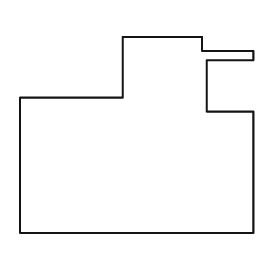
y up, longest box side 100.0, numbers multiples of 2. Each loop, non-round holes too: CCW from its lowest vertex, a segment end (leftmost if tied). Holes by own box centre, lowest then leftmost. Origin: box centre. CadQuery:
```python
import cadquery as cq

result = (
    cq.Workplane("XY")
    .moveTo(-50.0, -42.0)
    .lineTo(50.0, -42.0)
    .lineTo(50.0, 10.0)
    .lineTo(30.0, 10.0)
    .lineTo(30.0, 32.0)
    .lineTo(50.0, 32.0)
    .lineTo(50.0, 36.0)
    .lineTo(28.0, 36.0)
    .lineTo(28.0, 42.0)
    .lineTo(-6.0, 42.0)
    .lineTo(-6.0, 16.0)
    .lineTo(-50.0, 16.0)
    .close()
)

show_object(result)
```